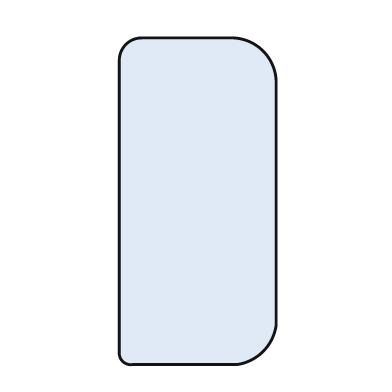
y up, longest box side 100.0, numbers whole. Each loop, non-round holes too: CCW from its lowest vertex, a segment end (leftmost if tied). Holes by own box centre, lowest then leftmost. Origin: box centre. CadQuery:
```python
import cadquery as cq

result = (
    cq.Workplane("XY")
    .moveTo(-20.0, -50.0)
    .lineTo(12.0, -50.0)
    .threePointArc((20.0, -46.0), (24.0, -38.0))
    .lineTo(24.0, 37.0)
    .threePointArc((20.0, 46.0), (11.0, 50.0))
    .lineTo(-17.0, 50.0)
    .threePointArc((-22.0, 48.0), (-24.0, 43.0))
    .lineTo(-24.0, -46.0)
    .threePointArc((-23.0, -49.0), (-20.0, -50.0))
    .close()
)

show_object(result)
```